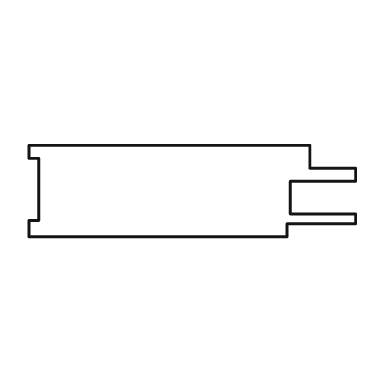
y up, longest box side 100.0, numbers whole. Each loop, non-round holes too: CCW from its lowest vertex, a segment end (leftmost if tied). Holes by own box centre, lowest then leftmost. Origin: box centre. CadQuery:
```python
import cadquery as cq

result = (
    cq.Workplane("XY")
    .moveTo(-50.0, -14.0)
    .lineTo(29.0, -14.0)
    .lineTo(29.0, -10.0)
    .lineTo(50.0, -10.0)
    .lineTo(50.0, -7.0)
    .lineTo(30.0, -7.0)
    .lineTo(30.0, 3.0)
    .lineTo(50.0, 3.0)
    .lineTo(50.0, 7.0)
    .lineTo(36.0, 7.0)
    .lineTo(36.0, 14.0)
    .lineTo(-50.0, 14.0)
    .lineTo(-50.0, 10.0)
    .lineTo(-47.0, 10.0)
    .lineTo(-47.0, -9.0)
    .lineTo(-50.0, -9.0)
    .close()
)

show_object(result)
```